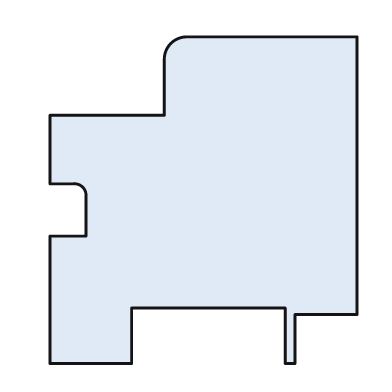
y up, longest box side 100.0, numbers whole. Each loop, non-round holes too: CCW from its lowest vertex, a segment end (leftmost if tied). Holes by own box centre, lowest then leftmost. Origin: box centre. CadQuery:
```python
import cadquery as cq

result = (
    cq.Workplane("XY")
    .moveTo(-47.0, -50.0)
    .lineTo(-22.0, -50.0)
    .lineTo(-22.0, -33.0)
    .lineTo(25.0, -33.0)
    .lineTo(25.0, -50.0)
    .lineTo(28.0, -50.0)
    .lineTo(28.0, -35.0)
    .lineTo(47.0, -35.0)
    .lineTo(47.0, 50.0)
    .lineTo(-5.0, 50.0)
    .threePointArc((-10.0, 48.0), (-12.0, 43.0))
    .lineTo(-12.0, 26.0)
    .lineTo(-47.0, 26.0)
    .lineTo(-47.0, 5.0)
    .lineTo(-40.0, 5.0)
    .threePointArc((-37.0, 4.0), (-36.0, 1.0))
    .lineTo(-36.0, -11.0)
    .lineTo(-47.0, -11.0)
    .close()
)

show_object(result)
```